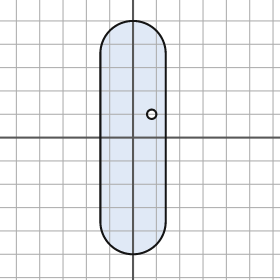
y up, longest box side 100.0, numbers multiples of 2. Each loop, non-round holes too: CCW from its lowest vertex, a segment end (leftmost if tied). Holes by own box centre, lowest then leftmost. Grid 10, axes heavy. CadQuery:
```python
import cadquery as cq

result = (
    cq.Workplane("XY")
    .moveTo(-14.0, -36.0)
    .threePointArc((0.0, -50.0), (14.0, -36.0))
    .lineTo(14.0, 36.0)
    .threePointArc((0.0, 50.0), (-14.0, 36.0))
    .close()
    .moveTo(8.0, 10.0)
    .circle(2.0)
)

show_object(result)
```